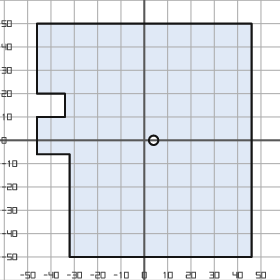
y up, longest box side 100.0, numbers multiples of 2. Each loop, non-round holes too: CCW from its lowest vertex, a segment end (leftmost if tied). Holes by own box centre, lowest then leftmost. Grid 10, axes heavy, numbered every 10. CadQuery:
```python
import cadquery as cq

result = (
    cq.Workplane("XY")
    .moveTo(-32.0, -50.0)
    .lineTo(46.0, -50.0)
    .lineTo(46.0, 50.0)
    .lineTo(-46.0, 50.0)
    .lineTo(-46.0, 20.0)
    .lineTo(-34.0, 20.0)
    .lineTo(-34.0, 10.0)
    .lineTo(-46.0, 10.0)
    .lineTo(-46.0, -6.0)
    .lineTo(-32.0, -6.0)
    .close()
    .moveTo(4.0, 0.0)
    .circle(2.0)
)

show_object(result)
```